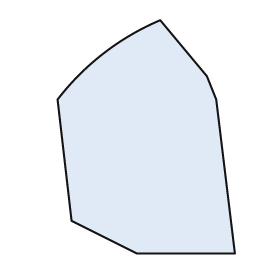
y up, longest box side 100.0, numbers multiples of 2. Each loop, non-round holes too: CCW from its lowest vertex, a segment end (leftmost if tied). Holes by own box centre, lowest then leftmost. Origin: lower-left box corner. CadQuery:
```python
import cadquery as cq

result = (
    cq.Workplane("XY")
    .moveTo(34.0, 0.0)
    .lineTo(76.0, 0.0)
    .lineTo(68.0, 66.0)
    .lineTo(64.0, 76.0)
    .lineTo(44.0, 100.0)
    .threePointArc((20.0, 86.0), (0.0, 66.0))
    .lineTo(6.0, 14.0)
    .close()
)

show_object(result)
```